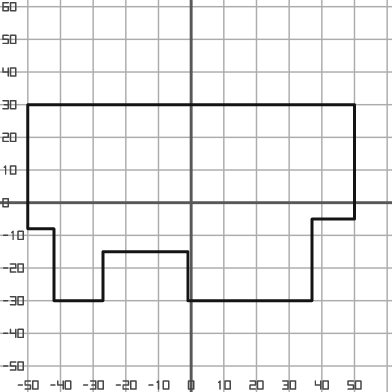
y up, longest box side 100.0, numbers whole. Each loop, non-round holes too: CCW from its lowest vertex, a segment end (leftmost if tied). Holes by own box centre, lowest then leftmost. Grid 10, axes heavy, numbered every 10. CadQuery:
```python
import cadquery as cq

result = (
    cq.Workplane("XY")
    .moveTo(-42.0, -30.0)
    .lineTo(-27.0, -30.0)
    .lineTo(-27.0, -15.0)
    .lineTo(-1.0, -15.0)
    .lineTo(-1.0, -30.0)
    .lineTo(37.0, -30.0)
    .lineTo(37.0, -5.0)
    .lineTo(50.0, -5.0)
    .lineTo(50.0, 30.0)
    .lineTo(-50.0, 30.0)
    .lineTo(-50.0, -8.0)
    .lineTo(-42.0, -8.0)
    .close()
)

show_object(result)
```